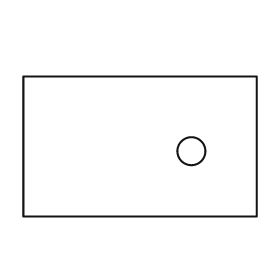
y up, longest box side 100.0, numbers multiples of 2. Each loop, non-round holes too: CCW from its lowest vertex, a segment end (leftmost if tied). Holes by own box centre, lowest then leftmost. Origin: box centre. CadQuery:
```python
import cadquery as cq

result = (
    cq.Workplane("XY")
    .moveTo(-50.0, -30.0)
    .lineTo(50.0, -30.0)
    .lineTo(50.0, 30.0)
    .lineTo(-50.0, 30.0)
    .close()
    .moveTo(22.0, -2.0)
    .circle(6.0)
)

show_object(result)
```